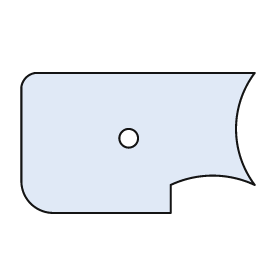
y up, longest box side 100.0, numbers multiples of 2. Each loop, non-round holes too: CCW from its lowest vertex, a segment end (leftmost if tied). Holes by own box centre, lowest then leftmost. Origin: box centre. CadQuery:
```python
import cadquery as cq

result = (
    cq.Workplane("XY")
    .moveTo(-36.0, -30.0)
    .lineTo(14.0, -30.0)
    .lineTo(14.0, -18.0)
    .threePointArc((32.0, -14.0), (50.0, -18.0))
    .threePointArc((42.0, 6.0), (50.0, 30.0))
    .lineTo(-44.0, 30.0)
    .threePointArc((-48.0, 28.0), (-50.0, 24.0))
    .lineTo(-50.0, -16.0)
    .threePointArc((-46.0, -26.0), (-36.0, -30.0))
    .close()
    .moveTo(-4.0, 2.0)
    .circle(4.0)
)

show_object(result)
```